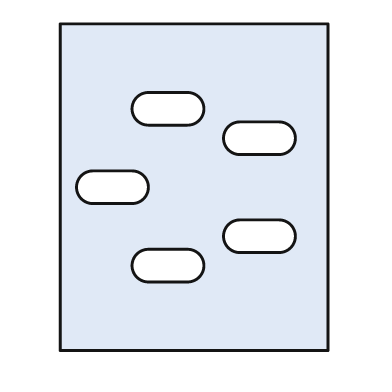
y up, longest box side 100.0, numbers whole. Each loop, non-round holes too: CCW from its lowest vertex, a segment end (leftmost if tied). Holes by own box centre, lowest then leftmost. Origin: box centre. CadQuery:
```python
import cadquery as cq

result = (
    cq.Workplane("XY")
    .moveTo(-41.0, -50.0)
    .lineTo(41.0, -50.0)
    .lineTo(41.0, 50.0)
    .lineTo(-41.0, 50.0)
    .close()
    .moveTo(-14.0, -29.0)
    .lineTo(-2.0, -29.0)
    .threePointArc((3.0, -24.0), (-2.0, -19.0))
    .lineTo(-14.0, -19.0)
    .threePointArc((-19.0, -24.0), (-14.0, -29.0))
    .close()
    .moveTo(14.0, -20.0)
    .lineTo(26.0, -20.0)
    .threePointArc((31.0, -15.0), (26.0, -10.0))
    .lineTo(14.0, -10.0)
    .threePointArc((9.0, -15.0), (14.0, -20.0))
    .close()
    .moveTo(-31.0, -5.0)
    .lineTo(-19.0, -5.0)
    .threePointArc((-14.0, 0.0), (-19.0, 5.0))
    .lineTo(-31.0, 5.0)
    .threePointArc((-36.0, 0.0), (-31.0, -5.0))
    .close()
    .moveTo(14.0, 10.0)
    .lineTo(26.0, 10.0)
    .threePointArc((31.0, 15.0), (26.0, 20.0))
    .lineTo(14.0, 20.0)
    .threePointArc((9.0, 15.0), (14.0, 10.0))
    .close()
    .moveTo(-14.0, 19.0)
    .lineTo(-2.0, 19.0)
    .threePointArc((3.0, 24.0), (-2.0, 29.0))
    .lineTo(-14.0, 29.0)
    .threePointArc((-19.0, 24.0), (-14.0, 19.0))
    .close()
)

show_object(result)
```